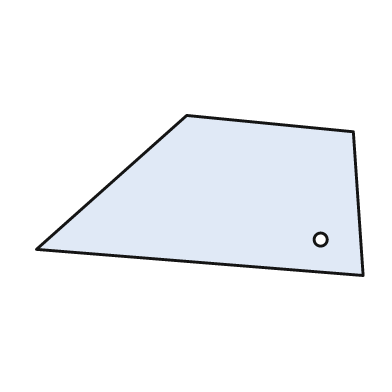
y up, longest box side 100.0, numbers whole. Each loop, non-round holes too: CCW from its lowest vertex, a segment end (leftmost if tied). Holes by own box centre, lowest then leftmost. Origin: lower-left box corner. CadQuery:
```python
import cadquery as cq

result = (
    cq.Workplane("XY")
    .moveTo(100.0, 0.0)
    .lineTo(97.0, 44.0)
    .lineTo(46.0, 49.0)
    .lineTo(0.0, 8.0)
    .close()
    .moveTo(87.0, 11.0)
    .circle(2.0)
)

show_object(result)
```